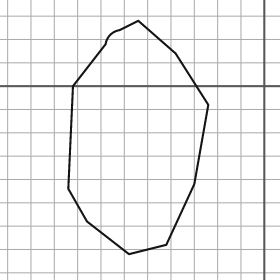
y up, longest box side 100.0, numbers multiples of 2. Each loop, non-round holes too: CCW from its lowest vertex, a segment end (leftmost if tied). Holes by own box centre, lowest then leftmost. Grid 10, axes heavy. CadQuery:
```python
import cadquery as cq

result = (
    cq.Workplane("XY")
    .moveTo(-58.0, -72.0)
    .lineTo(-42.0, -68.0)
    .lineTo(-30.0, -42.0)
    .lineTo(-24.0, -8.0)
    .lineTo(-38.0, 14.0)
    .lineTo(-54.0, 28.0)
    .lineTo(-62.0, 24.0)
    .threePointArc((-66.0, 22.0), (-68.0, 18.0))
    .lineTo(-82.0, 0.0)
    .lineTo(-84.0, -44.0)
    .lineTo(-76.0, -58.0)
    .close()
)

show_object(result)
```